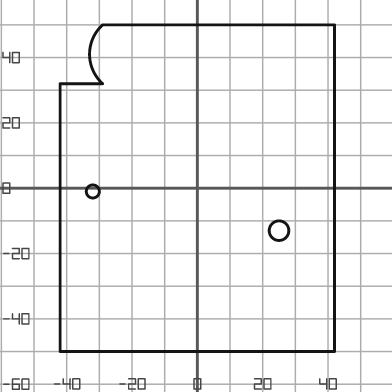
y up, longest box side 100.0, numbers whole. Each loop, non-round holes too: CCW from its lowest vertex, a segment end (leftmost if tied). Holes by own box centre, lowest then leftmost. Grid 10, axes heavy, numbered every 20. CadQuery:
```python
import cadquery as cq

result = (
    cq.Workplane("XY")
    .moveTo(-42.0, -50.0)
    .lineTo(42.0, -50.0)
    .lineTo(42.0, 50.0)
    .lineTo(-29.0, 50.0)
    .threePointArc((-33.0, 41.0), (-29.0, 32.0))
    .lineTo(-42.0, 32.0)
    .close()
    .moveTo(25.0, -13.0)
    .circle(3.0)
    .moveTo(-32.0, -1.0)
    .circle(2.0)
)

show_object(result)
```